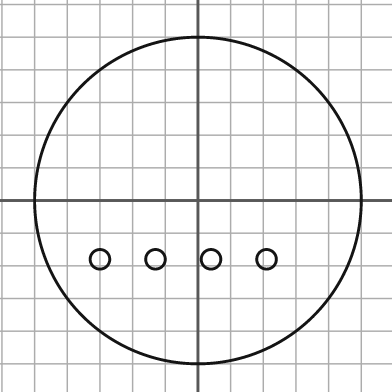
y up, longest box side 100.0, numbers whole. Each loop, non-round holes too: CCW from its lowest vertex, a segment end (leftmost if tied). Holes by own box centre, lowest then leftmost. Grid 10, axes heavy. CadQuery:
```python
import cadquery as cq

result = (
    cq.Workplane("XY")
    .moveTo(0.0, 0.0)
    .circle(50.0)
    .moveTo(-30.0, -18.0)
    .circle(3.0)
    .moveTo(-13.0, -18.0)
    .circle(3.0)
    .moveTo(4.0, -18.0)
    .circle(3.0)
    .moveTo(21.0, -18.0)
    .circle(3.0)
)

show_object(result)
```